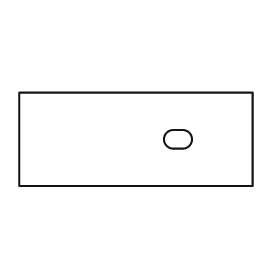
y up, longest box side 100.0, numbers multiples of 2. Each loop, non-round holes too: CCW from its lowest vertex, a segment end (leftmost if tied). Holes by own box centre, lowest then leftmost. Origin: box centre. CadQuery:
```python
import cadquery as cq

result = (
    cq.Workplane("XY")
    .moveTo(-50.0, -20.0)
    .lineTo(50.0, -20.0)
    .lineTo(50.0, 20.0)
    .lineTo(-50.0, 20.0)
    .close()
    .moveTo(16.0, -4.0)
    .lineTo(20.0, -4.0)
    .threePointArc((24.0, 0.0), (20.0, 4.0))
    .lineTo(16.0, 4.0)
    .threePointArc((12.0, 0.0), (16.0, -4.0))
    .close()
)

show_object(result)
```